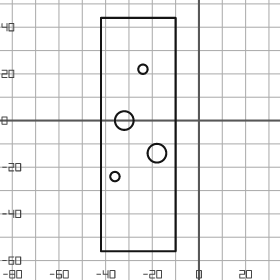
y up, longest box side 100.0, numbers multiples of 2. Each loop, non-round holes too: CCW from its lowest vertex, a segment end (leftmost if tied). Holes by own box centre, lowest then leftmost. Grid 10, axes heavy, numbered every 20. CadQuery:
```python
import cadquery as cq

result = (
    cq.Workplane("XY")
    .moveTo(-42.0, -56.0)
    .lineTo(-10.0, -56.0)
    .lineTo(-10.0, 44.0)
    .lineTo(-42.0, 44.0)
    .close()
    .moveTo(-36.0, -24.0)
    .circle(2.0)
    .moveTo(-18.0, -14.0)
    .circle(4.0)
    .moveTo(-32.0, 0.0)
    .circle(4.0)
    .moveTo(-24.0, 22.0)
    .circle(2.0)
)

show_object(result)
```